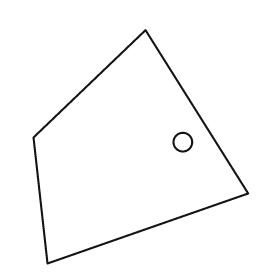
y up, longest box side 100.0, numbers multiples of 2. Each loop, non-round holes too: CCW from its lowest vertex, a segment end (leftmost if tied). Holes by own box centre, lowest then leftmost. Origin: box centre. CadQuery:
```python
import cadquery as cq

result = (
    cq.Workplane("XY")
    .moveTo(-40.0, -50.0)
    .lineTo(46.0, -20.0)
    .lineTo(2.0, 50.0)
    .lineTo(-46.0, 4.0)
    .close()
    .moveTo(18.0, 2.0)
    .circle(4.0)
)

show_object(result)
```